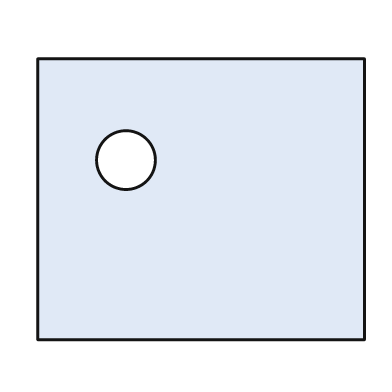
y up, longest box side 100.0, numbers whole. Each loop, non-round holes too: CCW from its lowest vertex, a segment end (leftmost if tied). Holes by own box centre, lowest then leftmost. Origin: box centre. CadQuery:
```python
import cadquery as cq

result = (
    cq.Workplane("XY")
    .moveTo(-50.0, -43.0)
    .lineTo(50.0, -43.0)
    .lineTo(50.0, 43.0)
    .lineTo(-50.0, 43.0)
    .close()
    .moveTo(-23.0, 12.0)
    .circle(9.0)
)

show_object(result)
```